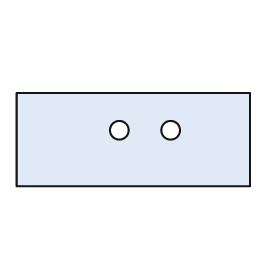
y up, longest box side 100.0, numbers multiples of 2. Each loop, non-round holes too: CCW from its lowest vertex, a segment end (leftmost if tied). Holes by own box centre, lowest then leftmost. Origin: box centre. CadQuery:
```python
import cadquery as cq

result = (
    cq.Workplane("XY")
    .moveTo(-50.0, -20.0)
    .lineTo(50.0, -20.0)
    .lineTo(50.0, 20.0)
    .lineTo(-50.0, 20.0)
    .close()
    .moveTo(-6.0, 4.0)
    .circle(4.0)
    .moveTo(16.0, 4.0)
    .circle(4.0)
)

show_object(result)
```